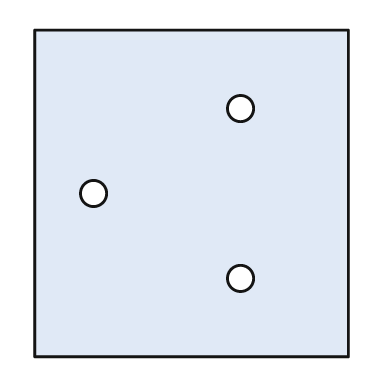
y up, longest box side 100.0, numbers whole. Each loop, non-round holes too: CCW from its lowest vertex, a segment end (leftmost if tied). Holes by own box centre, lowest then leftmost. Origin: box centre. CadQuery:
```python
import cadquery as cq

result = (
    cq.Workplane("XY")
    .moveTo(-48.0, -50.0)
    .lineTo(48.0, -50.0)
    .lineTo(48.0, 50.0)
    .lineTo(-48.0, 50.0)
    .close()
    .moveTo(15.0, -26.0)
    .circle(4.0)
    .moveTo(-30.0, 0.0)
    .circle(4.0)
    .moveTo(15.0, 26.0)
    .circle(4.0)
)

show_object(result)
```